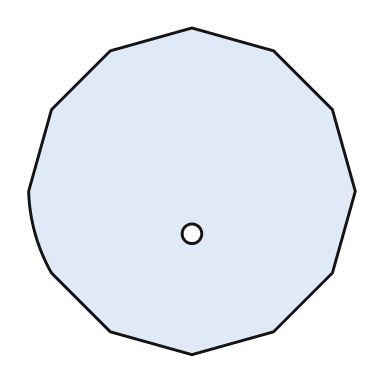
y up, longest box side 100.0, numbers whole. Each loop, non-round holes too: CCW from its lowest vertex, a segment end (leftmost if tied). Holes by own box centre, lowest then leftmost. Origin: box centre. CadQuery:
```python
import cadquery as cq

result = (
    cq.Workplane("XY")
    .moveTo(0.0, -50.0)
    .lineTo(25.0, -43.0)
    .lineTo(43.0, -25.0)
    .lineTo(50.0, 0.0)
    .lineTo(43.0, 25.0)
    .lineTo(25.0, 43.0)
    .lineTo(0.0, 50.0)
    .lineTo(-25.0, 43.0)
    .lineTo(-43.0, 25.0)
    .lineTo(-50.0, 0.0)
    .threePointArc((-48.0, -13.0), (-43.0, -25.0))
    .lineTo(-25.0, -43.0)
    .close()
    .moveTo(0.0, -13.0)
    .circle(3.0)
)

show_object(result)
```